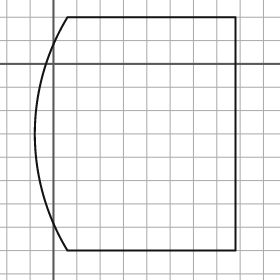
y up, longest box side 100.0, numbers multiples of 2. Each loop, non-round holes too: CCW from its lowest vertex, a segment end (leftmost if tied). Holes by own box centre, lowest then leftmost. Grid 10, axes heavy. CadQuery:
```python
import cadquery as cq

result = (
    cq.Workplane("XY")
    .moveTo(6.0, -80.0)
    .lineTo(78.0, -80.0)
    .lineTo(78.0, 20.0)
    .lineTo(6.0, 20.0)
    .threePointArc((-8.0, -30.0), (6.0, -80.0))
    .close()
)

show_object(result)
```